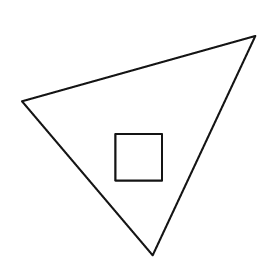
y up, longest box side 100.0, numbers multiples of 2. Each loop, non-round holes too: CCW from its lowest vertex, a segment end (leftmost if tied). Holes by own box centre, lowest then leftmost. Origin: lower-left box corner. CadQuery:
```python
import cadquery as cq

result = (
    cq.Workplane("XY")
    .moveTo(56.0, 0.0)
    .lineTo(100.0, 94.0)
    .lineTo(0.0, 66.0)
    .close()
    .moveTo(40.0, 32.0)
    .lineTo(60.0, 32.0)
    .lineTo(60.0, 52.0)
    .lineTo(40.0, 52.0)
    .close()
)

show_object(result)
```